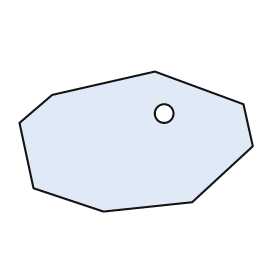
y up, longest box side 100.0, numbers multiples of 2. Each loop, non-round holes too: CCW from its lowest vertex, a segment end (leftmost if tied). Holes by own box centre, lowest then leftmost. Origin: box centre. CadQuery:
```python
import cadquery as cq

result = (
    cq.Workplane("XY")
    .moveTo(-14.0, -30.0)
    .lineTo(24.0, -26.0)
    .lineTo(50.0, -2.0)
    .lineTo(46.0, 16.0)
    .lineTo(8.0, 30.0)
    .lineTo(-36.0, 20.0)
    .lineTo(-50.0, 8.0)
    .lineTo(-44.0, -20.0)
    .close()
    .moveTo(12.0, 12.0)
    .circle(4.0)
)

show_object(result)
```